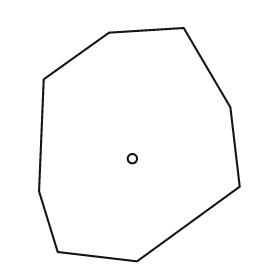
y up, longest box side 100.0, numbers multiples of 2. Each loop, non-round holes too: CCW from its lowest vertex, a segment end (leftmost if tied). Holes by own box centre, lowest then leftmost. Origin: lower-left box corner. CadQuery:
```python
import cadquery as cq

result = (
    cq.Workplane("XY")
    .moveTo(42.0, 0.0)
    .lineTo(86.0, 32.0)
    .lineTo(82.0, 66.0)
    .lineTo(62.0, 100.0)
    .lineTo(30.0, 98.0)
    .lineTo(2.0, 78.0)
    .lineTo(0.0, 30.0)
    .lineTo(8.0, 4.0)
    .close()
    .moveTo(40.0, 44.0)
    .circle(2.0)
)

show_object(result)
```